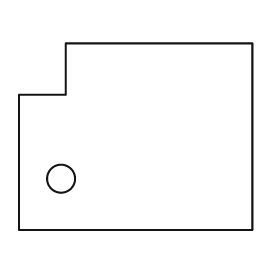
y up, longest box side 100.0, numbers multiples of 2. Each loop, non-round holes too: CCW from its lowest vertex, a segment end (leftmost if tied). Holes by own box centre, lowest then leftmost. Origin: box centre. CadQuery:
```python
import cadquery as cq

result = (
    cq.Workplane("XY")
    .moveTo(-50.0, -40.0)
    .lineTo(50.0, -40.0)
    .lineTo(50.0, 40.0)
    .lineTo(-30.0, 40.0)
    .lineTo(-30.0, 18.0)
    .lineTo(-50.0, 18.0)
    .close()
    .moveTo(-32.0, -18.0)
    .circle(6.0)
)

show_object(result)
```